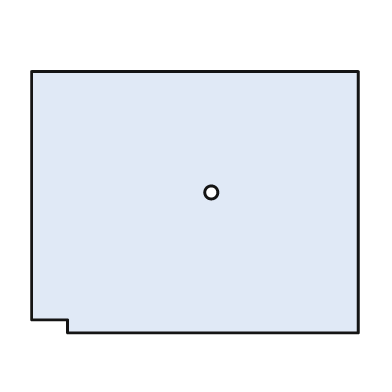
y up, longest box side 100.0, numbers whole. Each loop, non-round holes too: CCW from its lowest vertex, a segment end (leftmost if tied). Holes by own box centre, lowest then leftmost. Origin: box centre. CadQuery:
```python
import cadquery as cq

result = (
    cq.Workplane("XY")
    .moveTo(-39.0, -40.0)
    .lineTo(50.0, -40.0)
    .lineTo(50.0, 40.0)
    .lineTo(-50.0, 40.0)
    .lineTo(-50.0, -36.0)
    .lineTo(-39.0, -36.0)
    .close()
    .moveTo(5.0, 3.0)
    .circle(2.0)
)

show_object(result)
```